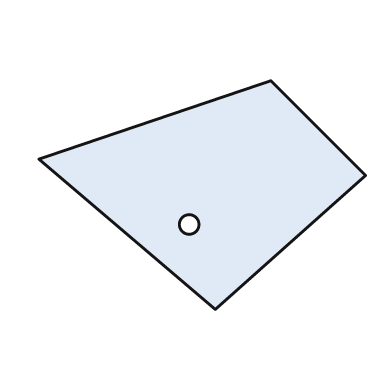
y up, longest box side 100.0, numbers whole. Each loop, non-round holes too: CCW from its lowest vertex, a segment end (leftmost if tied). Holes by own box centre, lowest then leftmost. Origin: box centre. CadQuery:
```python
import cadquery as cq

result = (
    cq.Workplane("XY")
    .moveTo(4.0, -35.0)
    .lineTo(50.0, 6.0)
    .lineTo(21.0, 35.0)
    .lineTo(-50.0, 11.0)
    .close()
    .moveTo(-4.0, -9.0)
    .circle(3.0)
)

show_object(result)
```